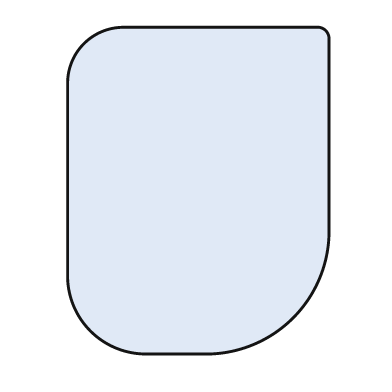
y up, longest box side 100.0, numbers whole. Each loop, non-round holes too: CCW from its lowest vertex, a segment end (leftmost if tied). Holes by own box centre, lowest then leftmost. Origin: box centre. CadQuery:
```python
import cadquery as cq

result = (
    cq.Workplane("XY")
    .moveTo(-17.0, -50.0)
    .lineTo(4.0, -50.0)
    .threePointArc((29.0, -39.0), (40.0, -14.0))
    .lineTo(40.0, 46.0)
    .threePointArc((39.0, 49.0), (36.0, 50.0))
    .lineTo(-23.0, 50.0)
    .threePointArc((-35.0, 45.0), (-40.0, 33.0))
    .lineTo(-40.0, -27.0)
    .threePointArc((-33.0, -43.0), (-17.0, -50.0))
    .close()
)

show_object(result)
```